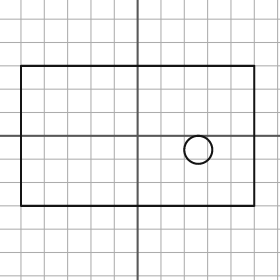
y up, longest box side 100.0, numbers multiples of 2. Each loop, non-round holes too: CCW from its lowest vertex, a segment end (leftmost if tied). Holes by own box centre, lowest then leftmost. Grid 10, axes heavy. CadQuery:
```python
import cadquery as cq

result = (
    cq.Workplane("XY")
    .moveTo(-50.0, -30.0)
    .lineTo(50.0, -30.0)
    .lineTo(50.0, 30.0)
    .lineTo(-50.0, 30.0)
    .close()
    .moveTo(26.0, -6.0)
    .circle(6.0)
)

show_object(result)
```